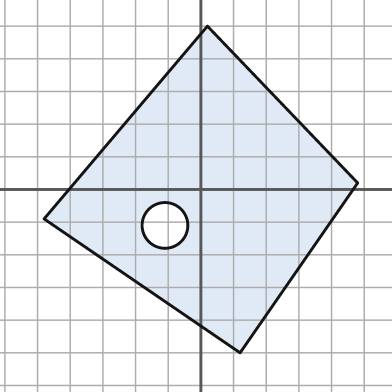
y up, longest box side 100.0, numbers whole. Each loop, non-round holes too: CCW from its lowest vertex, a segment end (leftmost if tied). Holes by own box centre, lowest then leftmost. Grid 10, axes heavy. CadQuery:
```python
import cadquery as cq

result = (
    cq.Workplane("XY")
    .moveTo(12.0, -50.0)
    .lineTo(48.0, 2.0)
    .lineTo(2.0, 50.0)
    .lineTo(-48.0, -9.0)
    .close()
    .moveTo(-11.0, -11.0)
    .circle(7.0)
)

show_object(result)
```